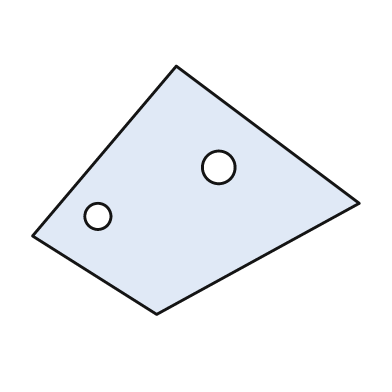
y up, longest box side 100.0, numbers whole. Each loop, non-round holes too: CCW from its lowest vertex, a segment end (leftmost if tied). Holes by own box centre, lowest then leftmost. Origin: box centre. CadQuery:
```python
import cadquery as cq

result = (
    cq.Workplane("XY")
    .moveTo(-12.0, -38.0)
    .lineTo(50.0, -4.0)
    .lineTo(-6.0, 38.0)
    .lineTo(-50.0, -14.0)
    .close()
    .moveTo(-30.0, -8.0)
    .circle(4.0)
    .moveTo(7.0, 7.0)
    .circle(5.0)
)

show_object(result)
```